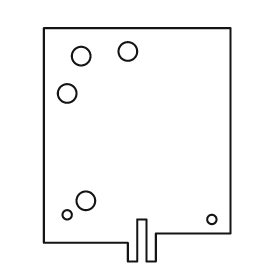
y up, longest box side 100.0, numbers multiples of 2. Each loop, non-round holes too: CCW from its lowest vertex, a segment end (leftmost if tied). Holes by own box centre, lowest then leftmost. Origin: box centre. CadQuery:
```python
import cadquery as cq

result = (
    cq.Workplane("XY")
    .moveTo(-4.0, -50.0)
    .lineTo(0.0, -50.0)
    .lineTo(0.0, -32.0)
    .lineTo(4.0, -32.0)
    .lineTo(4.0, -50.0)
    .lineTo(8.0, -50.0)
    .lineTo(8.0, -38.0)
    .lineTo(40.0, -38.0)
    .lineTo(40.0, 50.0)
    .lineTo(-40.0, 50.0)
    .lineTo(-40.0, -42.0)
    .lineTo(-4.0, -42.0)
    .close()
    .moveTo(32.0, -32.0)
    .circle(2.0)
    .moveTo(-30.0, -30.0)
    .circle(2.0)
    .moveTo(-22.0, -24.0)
    .circle(4.0)
    .moveTo(-30.0, 22.0)
    .circle(4.0)
    .moveTo(-24.0, 38.0)
    .circle(4.0)
    .moveTo(-4.0, 40.0)
    .circle(4.0)
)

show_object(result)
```